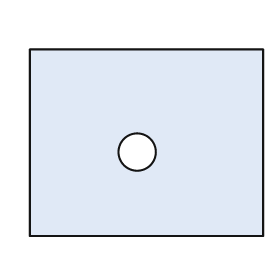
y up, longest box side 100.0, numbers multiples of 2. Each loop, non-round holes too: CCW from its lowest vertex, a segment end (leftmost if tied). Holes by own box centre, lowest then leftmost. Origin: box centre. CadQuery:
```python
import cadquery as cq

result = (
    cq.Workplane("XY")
    .moveTo(-50.0, -40.0)
    .lineTo(50.0, -40.0)
    .lineTo(50.0, 40.0)
    .lineTo(-50.0, 40.0)
    .close()
    .moveTo(-4.0, -4.0)
    .circle(8.0)
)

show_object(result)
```